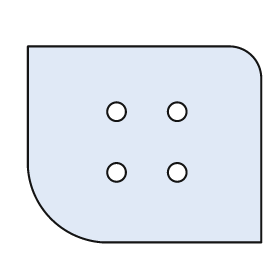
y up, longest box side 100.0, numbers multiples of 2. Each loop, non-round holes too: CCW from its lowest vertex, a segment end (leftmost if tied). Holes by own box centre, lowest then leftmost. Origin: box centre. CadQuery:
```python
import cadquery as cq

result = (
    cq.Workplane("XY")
    .moveTo(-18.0, -42.0)
    .lineTo(50.0, -42.0)
    .lineTo(50.0, 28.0)
    .threePointArc((46.0, 38.0), (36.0, 42.0))
    .lineTo(-50.0, 42.0)
    .lineTo(-50.0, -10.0)
    .threePointArc((-40.0, -32.0), (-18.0, -42.0))
    .close()
    .moveTo(-12.0, -12.0)
    .circle(4.0)
    .moveTo(14.0, -12.0)
    .circle(4.0)
    .moveTo(-12.0, 14.0)
    .circle(4.0)
    .moveTo(14.0, 14.0)
    .circle(4.0)
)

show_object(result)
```